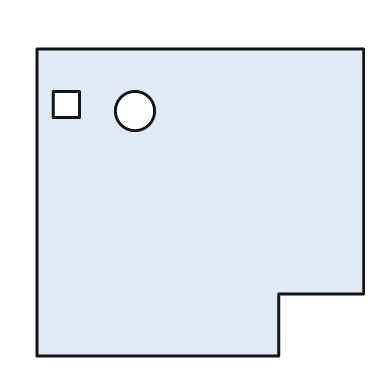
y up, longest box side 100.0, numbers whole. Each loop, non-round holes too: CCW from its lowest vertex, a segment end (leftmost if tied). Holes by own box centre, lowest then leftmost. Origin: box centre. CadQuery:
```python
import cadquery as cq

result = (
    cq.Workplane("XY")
    .moveTo(-50.0, -47.0)
    .lineTo(24.0, -47.0)
    .lineTo(24.0, -28.0)
    .lineTo(50.0, -28.0)
    .lineTo(50.0, 47.0)
    .lineTo(-50.0, 47.0)
    .close()
    .moveTo(-20.0, 28.0)
    .circle(6.0)
    .moveTo(-45.0, 26.0)
    .lineTo(-37.0, 26.0)
    .lineTo(-37.0, 34.0)
    .lineTo(-45.0, 34.0)
    .close()
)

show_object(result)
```